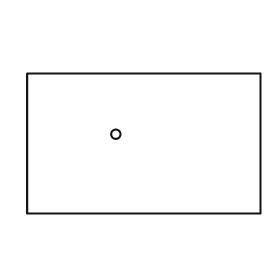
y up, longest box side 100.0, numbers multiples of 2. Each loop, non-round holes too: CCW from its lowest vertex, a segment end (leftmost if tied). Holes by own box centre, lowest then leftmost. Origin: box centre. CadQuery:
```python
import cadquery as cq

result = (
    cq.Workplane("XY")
    .moveTo(-50.0, -30.0)
    .lineTo(50.0, -30.0)
    .lineTo(50.0, 30.0)
    .lineTo(-50.0, 30.0)
    .close()
    .moveTo(-12.0, 4.0)
    .circle(2.0)
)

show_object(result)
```